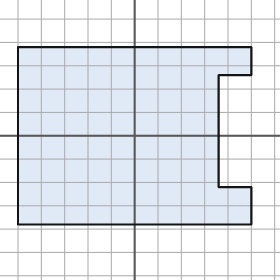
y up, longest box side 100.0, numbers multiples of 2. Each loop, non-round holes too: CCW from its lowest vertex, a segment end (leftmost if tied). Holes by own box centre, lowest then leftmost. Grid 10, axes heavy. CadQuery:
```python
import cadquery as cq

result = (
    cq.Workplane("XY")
    .moveTo(-50.0, -38.0)
    .lineTo(50.0, -38.0)
    .lineTo(50.0, -22.0)
    .lineTo(36.0, -22.0)
    .lineTo(36.0, 26.0)
    .lineTo(50.0, 26.0)
    .lineTo(50.0, 38.0)
    .lineTo(-50.0, 38.0)
    .close()
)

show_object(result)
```